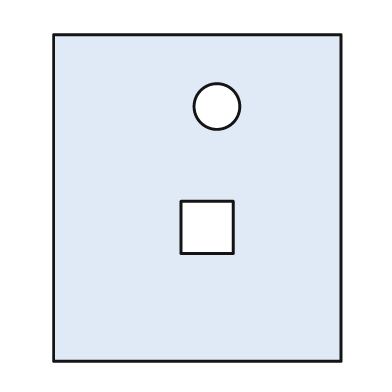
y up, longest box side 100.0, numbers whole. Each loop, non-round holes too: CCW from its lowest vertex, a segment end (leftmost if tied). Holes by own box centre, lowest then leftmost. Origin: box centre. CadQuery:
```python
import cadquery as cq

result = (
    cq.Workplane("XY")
    .moveTo(-44.0, -50.0)
    .lineTo(44.0, -50.0)
    .lineTo(44.0, 50.0)
    .lineTo(-44.0, 50.0)
    .close()
    .moveTo(-5.0, -17.0)
    .lineTo(11.0, -17.0)
    .lineTo(11.0, -1.0)
    .lineTo(-5.0, -1.0)
    .close()
    .moveTo(6.0, 28.0)
    .circle(7.0)
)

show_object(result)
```